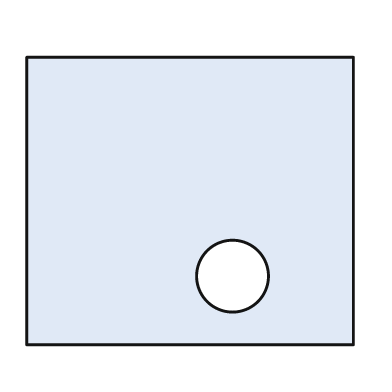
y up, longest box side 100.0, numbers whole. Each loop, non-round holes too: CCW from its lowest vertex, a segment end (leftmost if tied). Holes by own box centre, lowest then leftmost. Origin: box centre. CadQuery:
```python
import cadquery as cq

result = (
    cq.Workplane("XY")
    .moveTo(-50.0, -44.0)
    .lineTo(50.0, -44.0)
    .lineTo(50.0, 44.0)
    .lineTo(-50.0, 44.0)
    .close()
    .moveTo(13.0, -23.0)
    .circle(11.0)
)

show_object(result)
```